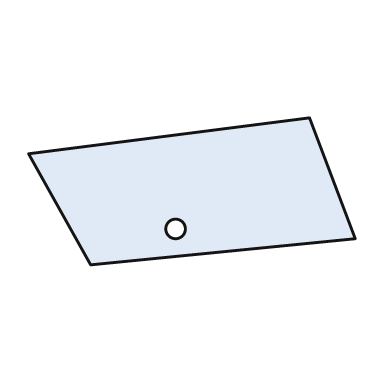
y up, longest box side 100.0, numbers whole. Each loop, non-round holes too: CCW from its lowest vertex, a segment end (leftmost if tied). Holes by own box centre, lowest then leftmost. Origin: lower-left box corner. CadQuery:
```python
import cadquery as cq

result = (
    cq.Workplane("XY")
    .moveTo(19.0, 0.0)
    .lineTo(100.0, 8.0)
    .lineTo(86.0, 45.0)
    .lineTo(0.0, 34.0)
    .close()
    .moveTo(45.0, 11.0)
    .circle(3.0)
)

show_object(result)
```